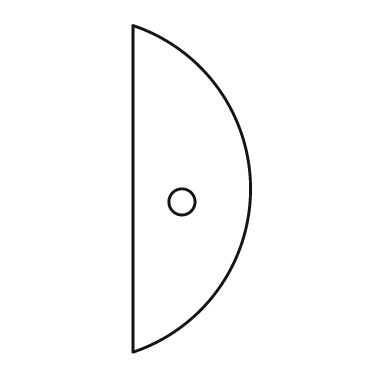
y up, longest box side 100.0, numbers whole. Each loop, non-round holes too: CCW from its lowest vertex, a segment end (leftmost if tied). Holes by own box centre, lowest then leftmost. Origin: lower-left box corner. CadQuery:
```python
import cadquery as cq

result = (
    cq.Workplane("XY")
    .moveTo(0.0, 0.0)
    .threePointArc((36.0, 50.0), (0.0, 100.0))
    .close()
    .moveTo(15.0, 46.0)
    .circle(4.0)
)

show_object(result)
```